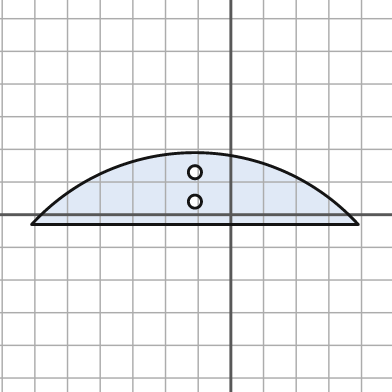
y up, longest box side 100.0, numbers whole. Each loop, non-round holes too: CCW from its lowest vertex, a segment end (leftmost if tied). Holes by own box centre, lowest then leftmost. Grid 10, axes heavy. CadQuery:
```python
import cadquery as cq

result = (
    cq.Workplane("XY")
    .moveTo(-61.0, -3.0)
    .lineTo(39.0, -3.0)
    .threePointArc((-11.0, 19.0), (-61.0, -3.0))
    .close()
    .moveTo(-11.0, 4.0)
    .circle(2.0)
    .moveTo(-11.0, 13.0)
    .circle(2.0)
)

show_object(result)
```